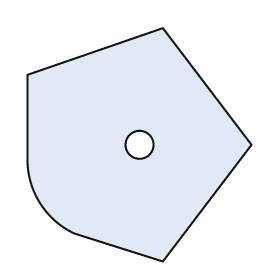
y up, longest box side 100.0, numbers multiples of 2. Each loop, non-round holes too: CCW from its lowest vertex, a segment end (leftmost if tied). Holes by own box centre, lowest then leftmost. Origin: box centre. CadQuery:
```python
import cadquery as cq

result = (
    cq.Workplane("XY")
    .moveTo(10.0, -50.0)
    .lineTo(48.0, 0.0)
    .lineTo(10.0, 50.0)
    .lineTo(-48.0, 30.0)
    .lineTo(-48.0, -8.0)
    .threePointArc((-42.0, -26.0), (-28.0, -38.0))
    .close()
    .moveTo(0.0, 0.0)
    .circle(6.0)
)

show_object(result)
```